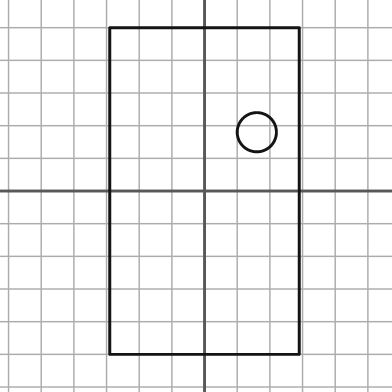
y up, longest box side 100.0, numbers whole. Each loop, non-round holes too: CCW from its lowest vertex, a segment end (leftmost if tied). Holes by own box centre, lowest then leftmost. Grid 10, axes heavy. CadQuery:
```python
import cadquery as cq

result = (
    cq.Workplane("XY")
    .moveTo(-29.0, -50.0)
    .lineTo(29.0, -50.0)
    .lineTo(29.0, 50.0)
    .lineTo(-29.0, 50.0)
    .close()
    .moveTo(16.0, 18.0)
    .circle(6.0)
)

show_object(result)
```